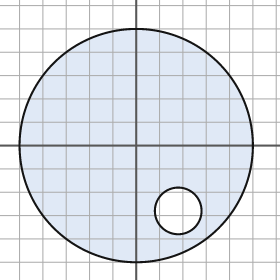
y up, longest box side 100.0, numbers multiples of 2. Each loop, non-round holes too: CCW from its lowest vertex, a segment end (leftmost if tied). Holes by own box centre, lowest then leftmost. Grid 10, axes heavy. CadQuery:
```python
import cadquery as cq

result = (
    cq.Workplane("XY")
    .moveTo(0.0, 0.0)
    .circle(50.0)
    .moveTo(18.0, -28.0)
    .circle(10.0)
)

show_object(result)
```